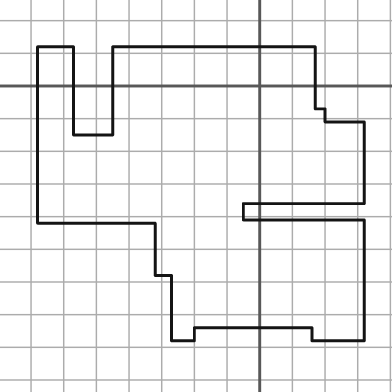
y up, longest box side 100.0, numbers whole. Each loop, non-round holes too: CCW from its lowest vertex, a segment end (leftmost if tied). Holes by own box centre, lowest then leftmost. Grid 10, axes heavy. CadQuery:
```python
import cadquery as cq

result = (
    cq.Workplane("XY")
    .moveTo(-27.0, -78.0)
    .lineTo(-20.0, -78.0)
    .lineTo(-20.0, -74.0)
    .lineTo(16.0, -74.0)
    .lineTo(16.0, -78.0)
    .lineTo(32.0, -78.0)
    .lineTo(32.0, -41.0)
    .lineTo(-5.0, -41.0)
    .lineTo(-5.0, -36.0)
    .lineTo(32.0, -36.0)
    .lineTo(32.0, -11.0)
    .lineTo(20.0, -11.0)
    .lineTo(20.0, -7.0)
    .lineTo(17.0, -7.0)
    .lineTo(17.0, 12.0)
    .lineTo(-45.0, 12.0)
    .lineTo(-45.0, -15.0)
    .lineTo(-57.0, -15.0)
    .lineTo(-57.0, 12.0)
    .lineTo(-68.0, 12.0)
    .lineTo(-68.0, -42.0)
    .lineTo(-32.0, -42.0)
    .lineTo(-32.0, -58.0)
    .lineTo(-27.0, -58.0)
    .close()
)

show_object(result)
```